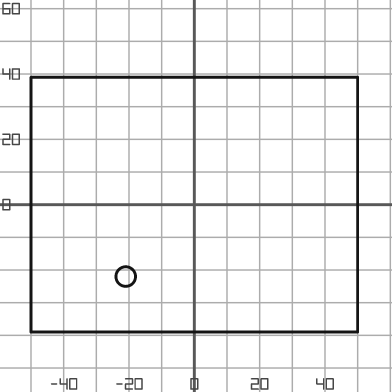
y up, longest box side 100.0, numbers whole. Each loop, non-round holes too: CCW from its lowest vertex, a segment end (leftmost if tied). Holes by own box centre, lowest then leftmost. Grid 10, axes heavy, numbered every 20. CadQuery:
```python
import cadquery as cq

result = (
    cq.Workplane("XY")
    .moveTo(-50.0, -39.0)
    .lineTo(50.0, -39.0)
    .lineTo(50.0, 39.0)
    .lineTo(-50.0, 39.0)
    .close()
    .moveTo(-21.0, -22.0)
    .circle(3.0)
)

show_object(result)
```